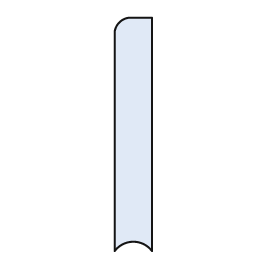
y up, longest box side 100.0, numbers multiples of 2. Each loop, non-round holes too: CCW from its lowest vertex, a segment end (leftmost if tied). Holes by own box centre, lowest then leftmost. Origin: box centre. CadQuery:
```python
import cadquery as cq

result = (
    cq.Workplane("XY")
    .moveTo(-8.0, -50.0)
    .threePointArc((0.0, -46.0), (8.0, -50.0))
    .lineTo(8.0, 50.0)
    .lineTo(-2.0, 50.0)
    .threePointArc((-6.0, 48.0), (-8.0, 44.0))
    .close()
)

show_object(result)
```